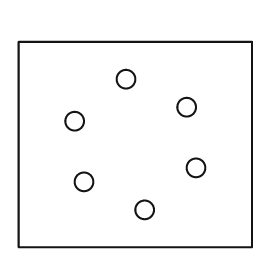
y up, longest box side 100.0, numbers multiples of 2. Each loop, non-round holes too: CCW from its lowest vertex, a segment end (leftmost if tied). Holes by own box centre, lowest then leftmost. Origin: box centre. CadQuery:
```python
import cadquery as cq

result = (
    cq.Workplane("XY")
    .moveTo(-50.0, -44.0)
    .lineTo(50.0, -44.0)
    .lineTo(50.0, 44.0)
    .lineTo(-50.0, 44.0)
    .close()
    .moveTo(4.0, -28.0)
    .circle(4.0)
    .moveTo(-22.0, -16.0)
    .circle(4.0)
    .moveTo(26.0, -10.0)
    .circle(4.0)
    .moveTo(-26.0, 10.0)
    .circle(4.0)
    .moveTo(22.0, 16.0)
    .circle(4.0)
    .moveTo(-4.0, 28.0)
    .circle(4.0)
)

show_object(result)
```